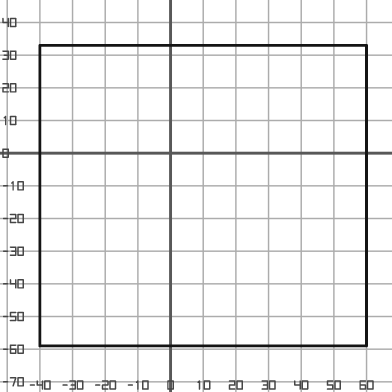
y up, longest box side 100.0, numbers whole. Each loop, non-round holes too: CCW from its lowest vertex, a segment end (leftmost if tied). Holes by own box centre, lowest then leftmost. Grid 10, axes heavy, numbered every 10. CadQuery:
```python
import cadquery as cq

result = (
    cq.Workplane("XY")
    .moveTo(-40.0, -59.0)
    .lineTo(60.0, -59.0)
    .lineTo(60.0, 33.0)
    .lineTo(-40.0, 33.0)
    .close()
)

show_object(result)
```